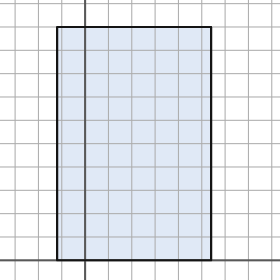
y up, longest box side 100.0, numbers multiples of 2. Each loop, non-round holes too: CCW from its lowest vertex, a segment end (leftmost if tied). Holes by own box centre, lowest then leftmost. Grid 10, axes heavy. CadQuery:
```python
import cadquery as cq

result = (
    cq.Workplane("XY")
    .moveTo(-12.0, 0.0)
    .lineTo(54.0, 0.0)
    .lineTo(54.0, 100.0)
    .lineTo(-12.0, 100.0)
    .close()
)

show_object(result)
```